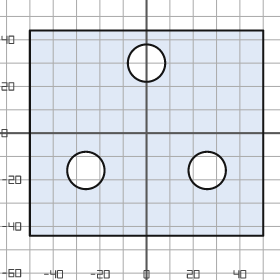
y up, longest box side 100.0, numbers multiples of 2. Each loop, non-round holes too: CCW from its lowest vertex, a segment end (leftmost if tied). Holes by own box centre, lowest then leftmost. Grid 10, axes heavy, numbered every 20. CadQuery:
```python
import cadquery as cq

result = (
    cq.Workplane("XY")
    .moveTo(-50.0, -44.0)
    .lineTo(50.0, -44.0)
    .lineTo(50.0, 44.0)
    .lineTo(-50.0, 44.0)
    .close()
    .moveTo(-26.0, -16.0)
    .circle(8.0)
    .moveTo(26.0, -16.0)
    .circle(8.0)
    .moveTo(0.0, 30.0)
    .circle(8.0)
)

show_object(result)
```